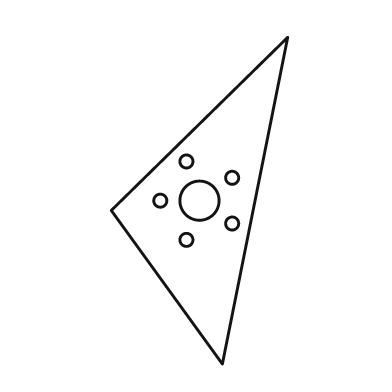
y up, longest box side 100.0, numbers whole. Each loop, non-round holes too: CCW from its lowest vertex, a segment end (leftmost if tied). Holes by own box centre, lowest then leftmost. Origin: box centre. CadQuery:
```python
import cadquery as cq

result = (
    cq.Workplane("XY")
    .moveTo(7.0, -50.0)
    .lineTo(27.0, 50.0)
    .lineTo(-27.0, -3.0)
    .close()
    .moveTo(-4.0, -12.0)
    .circle(2.0)
    .moveTo(10.0, -7.0)
    .circle(2.0)
    .moveTo(-12.0, 0.0)
    .circle(2.0)
    .moveTo(0.0, 0.0)
    .circle(6.0)
    .moveTo(10.0, 7.0)
    .circle(2.0)
    .moveTo(-4.0, 12.0)
    .circle(2.0)
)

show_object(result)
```